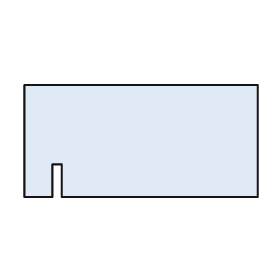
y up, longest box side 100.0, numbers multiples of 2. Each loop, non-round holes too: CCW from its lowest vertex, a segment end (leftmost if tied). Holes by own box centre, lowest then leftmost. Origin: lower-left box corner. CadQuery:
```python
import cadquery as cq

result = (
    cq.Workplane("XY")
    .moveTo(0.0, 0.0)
    .lineTo(12.0, 0.0)
    .lineTo(12.0, 14.0)
    .lineTo(16.0, 14.0)
    .lineTo(16.0, 0.0)
    .lineTo(100.0, 0.0)
    .lineTo(100.0, 48.0)
    .lineTo(0.0, 48.0)
    .close()
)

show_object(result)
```